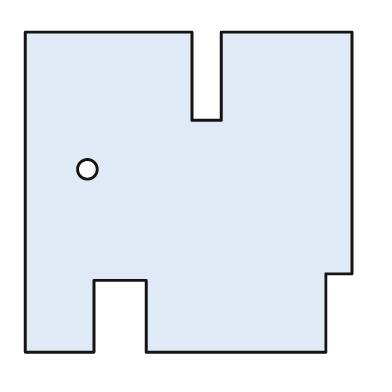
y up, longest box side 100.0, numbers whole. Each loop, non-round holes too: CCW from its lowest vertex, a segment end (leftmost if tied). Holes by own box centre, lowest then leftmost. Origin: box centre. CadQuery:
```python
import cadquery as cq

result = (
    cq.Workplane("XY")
    .moveTo(-50.0, -49.0)
    .lineTo(-29.0, -49.0)
    .lineTo(-29.0, -27.0)
    .lineTo(-13.0, -27.0)
    .lineTo(-13.0, -49.0)
    .lineTo(42.0, -49.0)
    .lineTo(42.0, -25.0)
    .lineTo(50.0, -25.0)
    .lineTo(50.0, 49.0)
    .lineTo(10.0, 49.0)
    .lineTo(10.0, 22.0)
    .lineTo(1.0, 22.0)
    .lineTo(1.0, 49.0)
    .lineTo(-50.0, 49.0)
    .close()
    .moveTo(-31.0, 7.0)
    .circle(3.0)
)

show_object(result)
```